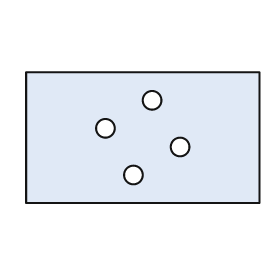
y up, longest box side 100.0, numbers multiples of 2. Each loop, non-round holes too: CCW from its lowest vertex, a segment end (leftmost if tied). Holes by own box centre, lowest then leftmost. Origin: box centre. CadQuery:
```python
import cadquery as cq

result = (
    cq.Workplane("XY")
    .moveTo(-50.0, -28.0)
    .lineTo(50.0, -28.0)
    .lineTo(50.0, 28.0)
    .lineTo(-50.0, 28.0)
    .close()
    .moveTo(-4.0, -16.0)
    .circle(4.0)
    .moveTo(16.0, -4.0)
    .circle(4.0)
    .moveTo(-16.0, 4.0)
    .circle(4.0)
    .moveTo(4.0, 16.0)
    .circle(4.0)
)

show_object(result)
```